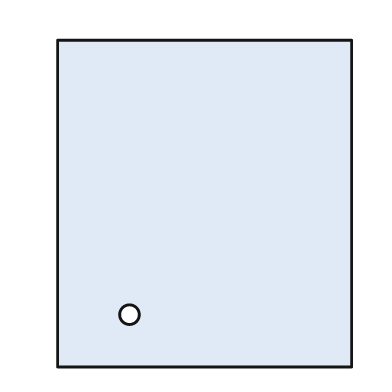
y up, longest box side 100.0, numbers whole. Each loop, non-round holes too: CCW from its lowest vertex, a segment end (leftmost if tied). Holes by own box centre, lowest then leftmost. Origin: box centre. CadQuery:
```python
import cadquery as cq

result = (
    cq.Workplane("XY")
    .moveTo(-45.0, -50.0)
    .lineTo(45.0, -50.0)
    .lineTo(45.0, 50.0)
    .lineTo(-45.0, 50.0)
    .close()
    .moveTo(-23.0, -34.0)
    .circle(3.0)
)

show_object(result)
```